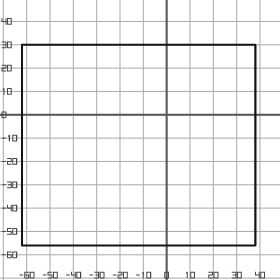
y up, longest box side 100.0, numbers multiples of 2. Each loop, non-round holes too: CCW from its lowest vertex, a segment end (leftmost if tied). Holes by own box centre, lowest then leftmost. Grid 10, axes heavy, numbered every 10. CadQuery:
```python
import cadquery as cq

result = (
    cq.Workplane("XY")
    .moveTo(-62.0, -56.0)
    .lineTo(38.0, -56.0)
    .lineTo(38.0, 30.0)
    .lineTo(-62.0, 30.0)
    .close()
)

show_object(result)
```